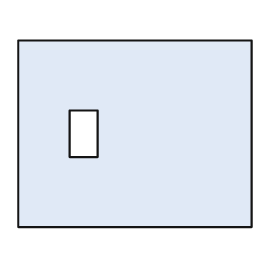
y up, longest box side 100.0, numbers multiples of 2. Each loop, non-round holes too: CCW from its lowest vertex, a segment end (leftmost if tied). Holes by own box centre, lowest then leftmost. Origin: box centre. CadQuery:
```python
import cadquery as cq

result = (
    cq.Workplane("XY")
    .moveTo(-50.0, -40.0)
    .lineTo(50.0, -40.0)
    .lineTo(50.0, 40.0)
    .lineTo(-50.0, 40.0)
    .close()
    .moveTo(-28.0, -10.0)
    .lineTo(-16.0, -10.0)
    .lineTo(-16.0, 10.0)
    .lineTo(-28.0, 10.0)
    .close()
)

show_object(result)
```